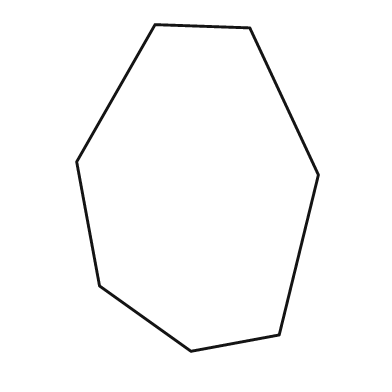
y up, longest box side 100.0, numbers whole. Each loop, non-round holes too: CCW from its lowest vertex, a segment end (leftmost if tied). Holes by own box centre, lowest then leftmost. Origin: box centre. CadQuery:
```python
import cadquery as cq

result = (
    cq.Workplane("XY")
    .moveTo(-2.0, -50.0)
    .lineTo(25.0, -45.0)
    .lineTo(37.0, 4.0)
    .lineTo(16.0, 49.0)
    .lineTo(-13.0, 50.0)
    .lineTo(-37.0, 8.0)
    .lineTo(-30.0, -30.0)
    .close()
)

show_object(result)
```